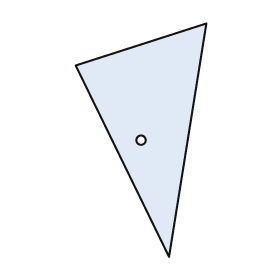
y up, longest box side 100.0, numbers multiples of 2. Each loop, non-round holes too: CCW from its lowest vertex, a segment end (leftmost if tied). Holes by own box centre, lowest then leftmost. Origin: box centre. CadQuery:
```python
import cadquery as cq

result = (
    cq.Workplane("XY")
    .moveTo(12.0, -50.0)
    .lineTo(28.0, 50.0)
    .lineTo(-28.0, 32.0)
    .close()
    .moveTo(0.0, 0.0)
    .circle(2.0)
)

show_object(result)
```